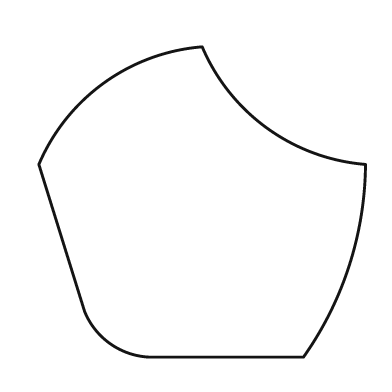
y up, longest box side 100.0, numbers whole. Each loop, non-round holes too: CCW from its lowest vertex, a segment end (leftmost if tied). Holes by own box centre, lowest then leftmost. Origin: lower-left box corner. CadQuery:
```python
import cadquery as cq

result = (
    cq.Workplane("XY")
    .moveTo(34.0, 0.0)
    .lineTo(81.0, 0.0)
    .threePointArc((95.0, 28.0), (100.0, 59.0))
    .threePointArc((70.0, 70.0), (50.0, 95.0))
    .threePointArc((20.0, 84.0), (0.0, 59.0))
    .lineTo(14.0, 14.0)
    .threePointArc((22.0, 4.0), (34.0, 0.0))
    .close()
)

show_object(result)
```